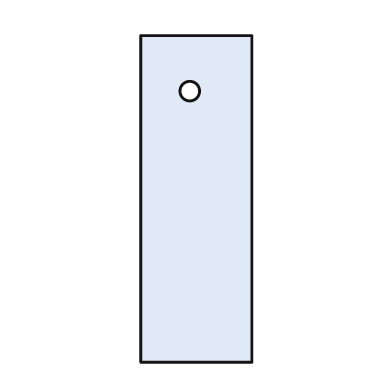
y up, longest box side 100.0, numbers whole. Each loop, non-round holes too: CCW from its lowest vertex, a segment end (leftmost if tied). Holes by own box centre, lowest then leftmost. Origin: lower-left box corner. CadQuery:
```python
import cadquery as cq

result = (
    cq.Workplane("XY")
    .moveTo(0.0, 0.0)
    .lineTo(34.0, 0.0)
    .lineTo(34.0, 100.0)
    .lineTo(0.0, 100.0)
    .close()
    .moveTo(15.0, 83.0)
    .circle(3.0)
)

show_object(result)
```